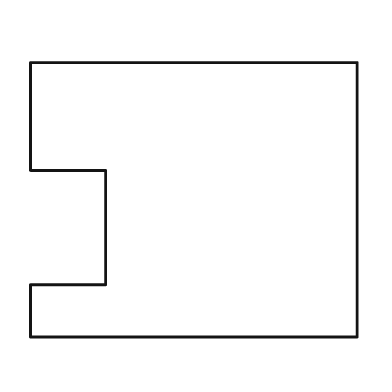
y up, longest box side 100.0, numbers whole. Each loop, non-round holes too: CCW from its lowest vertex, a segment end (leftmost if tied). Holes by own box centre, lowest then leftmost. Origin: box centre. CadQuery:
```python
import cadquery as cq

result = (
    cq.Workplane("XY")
    .moveTo(-50.0, -42.0)
    .lineTo(50.0, -42.0)
    .lineTo(50.0, 42.0)
    .lineTo(-50.0, 42.0)
    .lineTo(-50.0, 9.0)
    .lineTo(-27.0, 9.0)
    .lineTo(-27.0, -26.0)
    .lineTo(-50.0, -26.0)
    .close()
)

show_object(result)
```